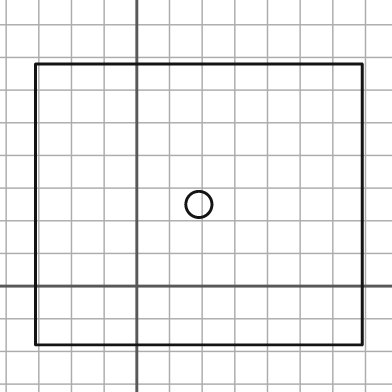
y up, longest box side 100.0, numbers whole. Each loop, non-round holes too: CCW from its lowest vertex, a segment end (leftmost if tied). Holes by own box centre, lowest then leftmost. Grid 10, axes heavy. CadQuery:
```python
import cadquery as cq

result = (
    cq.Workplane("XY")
    .moveTo(-31.0, -18.0)
    .lineTo(69.0, -18.0)
    .lineTo(69.0, 68.0)
    .lineTo(-31.0, 68.0)
    .close()
    .moveTo(19.0, 25.0)
    .circle(4.0)
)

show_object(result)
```